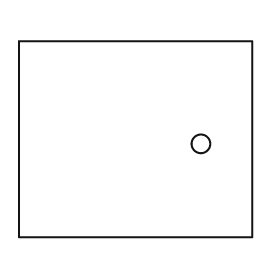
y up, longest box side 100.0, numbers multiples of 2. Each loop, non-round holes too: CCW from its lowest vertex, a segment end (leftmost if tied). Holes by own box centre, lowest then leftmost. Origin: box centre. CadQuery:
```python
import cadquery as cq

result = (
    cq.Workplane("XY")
    .moveTo(-50.0, -42.0)
    .lineTo(50.0, -42.0)
    .lineTo(50.0, 42.0)
    .lineTo(-50.0, 42.0)
    .close()
    .moveTo(28.0, -2.0)
    .circle(4.0)
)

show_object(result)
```